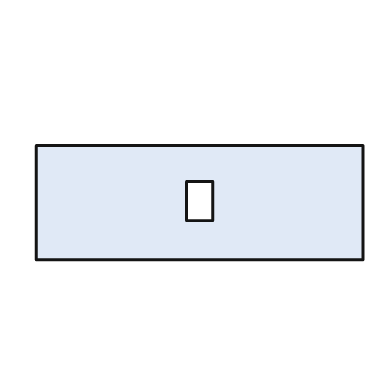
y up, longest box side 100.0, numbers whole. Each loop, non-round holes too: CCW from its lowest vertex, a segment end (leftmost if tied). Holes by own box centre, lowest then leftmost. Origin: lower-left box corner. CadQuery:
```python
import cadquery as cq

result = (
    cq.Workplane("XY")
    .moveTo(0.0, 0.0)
    .lineTo(100.0, 0.0)
    .lineTo(100.0, 35.0)
    .lineTo(0.0, 35.0)
    .close()
    .moveTo(46.0, 12.0)
    .lineTo(54.0, 12.0)
    .lineTo(54.0, 24.0)
    .lineTo(46.0, 24.0)
    .close()
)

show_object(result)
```